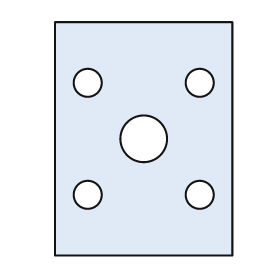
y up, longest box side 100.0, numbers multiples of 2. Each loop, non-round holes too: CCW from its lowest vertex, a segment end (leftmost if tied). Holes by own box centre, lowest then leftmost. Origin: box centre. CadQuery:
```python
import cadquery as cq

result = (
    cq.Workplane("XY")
    .moveTo(-38.0, -50.0)
    .lineTo(38.0, -50.0)
    .lineTo(38.0, 50.0)
    .lineTo(-38.0, 50.0)
    .close()
    .moveTo(-24.0, -24.0)
    .circle(6.0)
    .moveTo(24.0, -24.0)
    .circle(6.0)
    .moveTo(0.0, 0.0)
    .circle(10.0)
    .moveTo(-24.0, 24.0)
    .circle(6.0)
    .moveTo(24.0, 24.0)
    .circle(6.0)
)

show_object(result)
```